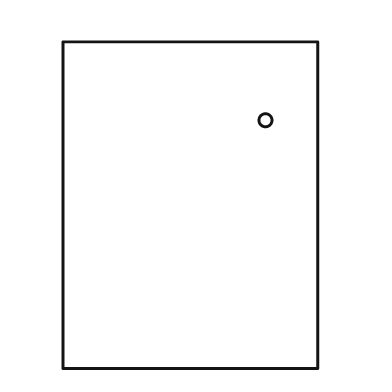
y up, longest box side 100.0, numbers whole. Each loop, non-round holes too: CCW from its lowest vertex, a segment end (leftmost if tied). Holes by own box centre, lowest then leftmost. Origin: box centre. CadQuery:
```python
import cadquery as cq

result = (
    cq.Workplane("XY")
    .moveTo(-39.0, -50.0)
    .lineTo(39.0, -50.0)
    .lineTo(39.0, 50.0)
    .lineTo(-39.0, 50.0)
    .close()
    .moveTo(23.0, 26.0)
    .circle(2.0)
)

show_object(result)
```